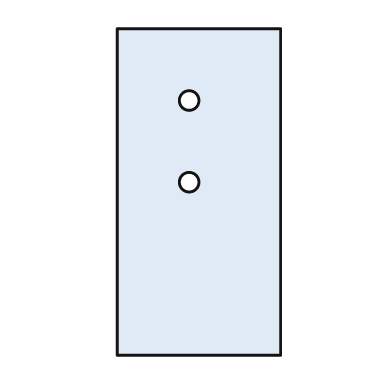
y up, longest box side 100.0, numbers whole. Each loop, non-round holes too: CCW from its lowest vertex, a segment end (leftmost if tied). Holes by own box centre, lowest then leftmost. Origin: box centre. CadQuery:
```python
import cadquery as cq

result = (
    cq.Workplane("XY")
    .moveTo(-25.0, -50.0)
    .lineTo(25.0, -50.0)
    .lineTo(25.0, 50.0)
    .lineTo(-25.0, 50.0)
    .close()
    .moveTo(-3.0, 3.0)
    .circle(3.0)
    .moveTo(-3.0, 28.0)
    .circle(3.0)
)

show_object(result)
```